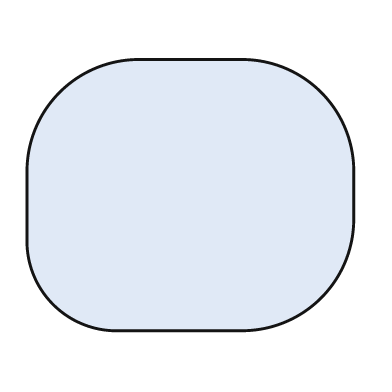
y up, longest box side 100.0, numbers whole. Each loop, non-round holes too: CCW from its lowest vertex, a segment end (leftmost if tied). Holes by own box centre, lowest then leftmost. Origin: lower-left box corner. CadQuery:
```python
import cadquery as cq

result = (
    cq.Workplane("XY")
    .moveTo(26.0, 0.0)
    .lineTo(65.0, 0.0)
    .threePointArc((90.0, 10.0), (100.0, 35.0))
    .lineTo(100.0, 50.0)
    .threePointArc((90.0, 73.0), (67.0, 83.0))
    .lineTo(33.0, 83.0)
    .threePointArc((10.0, 73.0), (0.0, 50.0))
    .lineTo(0.0, 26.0)
    .threePointArc((8.0, 8.0), (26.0, 0.0))
    .close()
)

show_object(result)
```